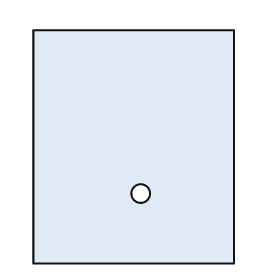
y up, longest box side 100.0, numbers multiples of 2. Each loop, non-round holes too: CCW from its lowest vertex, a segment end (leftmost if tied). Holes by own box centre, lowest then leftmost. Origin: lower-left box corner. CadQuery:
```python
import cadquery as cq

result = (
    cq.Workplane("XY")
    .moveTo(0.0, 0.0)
    .lineTo(86.0, 0.0)
    .lineTo(86.0, 100.0)
    .lineTo(0.0, 100.0)
    .close()
    .moveTo(46.0, 30.0)
    .circle(4.0)
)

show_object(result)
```